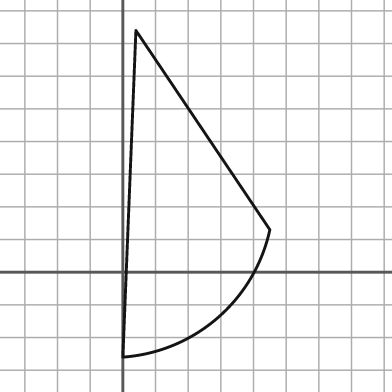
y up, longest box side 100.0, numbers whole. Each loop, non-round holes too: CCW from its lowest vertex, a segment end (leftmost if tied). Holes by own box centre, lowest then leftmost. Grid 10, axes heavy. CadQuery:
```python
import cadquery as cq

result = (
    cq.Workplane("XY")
    .moveTo(0.0, -26.0)
    .threePointArc((29.0, -14.0), (45.0, 13.0))
    .lineTo(4.0, 74.0)
    .close()
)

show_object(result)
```